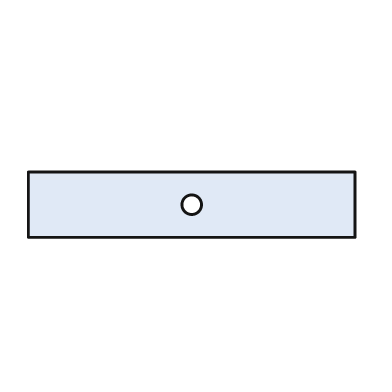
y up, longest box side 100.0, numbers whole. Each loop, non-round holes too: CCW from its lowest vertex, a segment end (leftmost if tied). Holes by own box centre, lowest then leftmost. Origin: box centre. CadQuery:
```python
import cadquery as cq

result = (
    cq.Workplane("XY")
    .moveTo(-50.0, -10.0)
    .lineTo(50.0, -10.0)
    .lineTo(50.0, 10.0)
    .lineTo(-50.0, 10.0)
    .close()
    .moveTo(0.0, 0.0)
    .circle(3.0)
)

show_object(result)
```